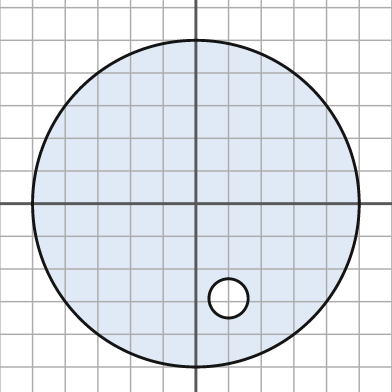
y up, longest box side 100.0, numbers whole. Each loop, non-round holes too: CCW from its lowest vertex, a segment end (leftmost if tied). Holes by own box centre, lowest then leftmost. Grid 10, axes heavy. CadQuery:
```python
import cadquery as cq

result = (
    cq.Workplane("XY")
    .moveTo(0.0, 0.0)
    .circle(50.0)
    .moveTo(10.0, -29.0)
    .circle(6.0)
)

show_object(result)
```